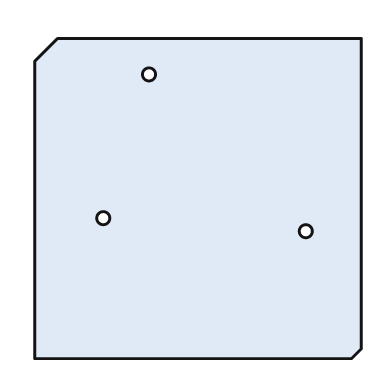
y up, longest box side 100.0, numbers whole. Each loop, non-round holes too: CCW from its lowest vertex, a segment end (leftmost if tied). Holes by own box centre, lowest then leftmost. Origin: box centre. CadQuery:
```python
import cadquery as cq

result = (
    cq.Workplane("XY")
    .moveTo(-50.0, -49.0)
    .lineTo(47.0, -49.0)
    .lineTo(50.0, -46.0)
    .lineTo(50.0, 49.0)
    .lineTo(-43.0, 49.0)
    .lineTo(-50.0, 42.0)
    .close()
    .moveTo(33.0, -10.0)
    .circle(2.0)
    .moveTo(-29.0, -6.0)
    .circle(2.0)
    .moveTo(-15.0, 38.0)
    .circle(2.0)
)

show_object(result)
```